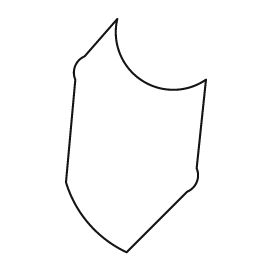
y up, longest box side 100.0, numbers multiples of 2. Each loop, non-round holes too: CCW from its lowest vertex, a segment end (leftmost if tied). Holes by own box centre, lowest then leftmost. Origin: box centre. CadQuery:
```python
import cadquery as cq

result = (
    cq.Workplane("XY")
    .moveTo(-4.0, -50.0)
    .lineTo(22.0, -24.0)
    .threePointArc((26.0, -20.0), (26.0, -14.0))
    .lineTo(30.0, 24.0)
    .threePointArc((2.0, 24.0), (-8.0, 50.0))
    .lineTo(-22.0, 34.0)
    .threePointArc((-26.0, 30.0), (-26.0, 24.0))
    .lineTo(-30.0, -20.0)
    .threePointArc((-20.0, -38.0), (-4.0, -50.0))
    .close()
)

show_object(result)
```